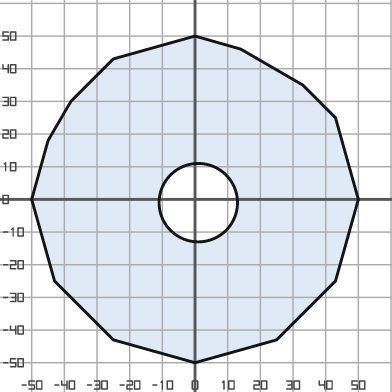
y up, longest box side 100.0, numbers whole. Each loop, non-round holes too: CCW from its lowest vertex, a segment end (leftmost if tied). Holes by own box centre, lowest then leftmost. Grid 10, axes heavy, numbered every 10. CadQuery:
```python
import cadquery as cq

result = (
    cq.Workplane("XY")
    .moveTo(0.0, -50.0)
    .lineTo(25.0, -43.0)
    .lineTo(43.0, -25.0)
    .lineTo(50.0, 0.0)
    .lineTo(43.0, 25.0)
    .lineTo(33.0, 35.0)
    .lineTo(14.0, 46.0)
    .lineTo(0.0, 50.0)
    .lineTo(-25.0, 43.0)
    .lineTo(-38.0, 30.0)
    .lineTo(-45.0, 18.0)
    .lineTo(-50.0, 0.0)
    .lineTo(-43.0, -25.0)
    .lineTo(-25.0, -43.0)
    .close()
    .moveTo(1.0, -1.0)
    .circle(12.0)
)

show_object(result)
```